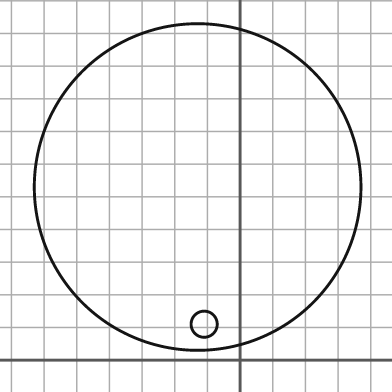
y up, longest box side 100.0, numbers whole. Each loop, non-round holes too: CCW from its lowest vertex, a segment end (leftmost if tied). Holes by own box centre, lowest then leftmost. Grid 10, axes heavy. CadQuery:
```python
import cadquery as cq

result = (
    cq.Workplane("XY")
    .moveTo(-13.0, 53.0)
    .circle(50.0)
    .moveTo(-11.0, 11.0)
    .circle(4.0)
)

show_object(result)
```